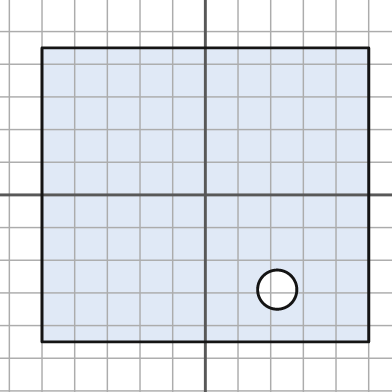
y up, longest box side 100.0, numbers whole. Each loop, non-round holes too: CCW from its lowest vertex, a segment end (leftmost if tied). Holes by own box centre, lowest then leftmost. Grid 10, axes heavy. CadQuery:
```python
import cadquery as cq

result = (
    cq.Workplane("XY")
    .moveTo(-50.0, -45.0)
    .lineTo(50.0, -45.0)
    .lineTo(50.0, 45.0)
    .lineTo(-50.0, 45.0)
    .close()
    .moveTo(22.0, -29.0)
    .circle(6.0)
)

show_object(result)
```